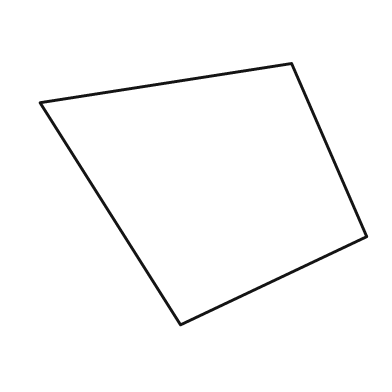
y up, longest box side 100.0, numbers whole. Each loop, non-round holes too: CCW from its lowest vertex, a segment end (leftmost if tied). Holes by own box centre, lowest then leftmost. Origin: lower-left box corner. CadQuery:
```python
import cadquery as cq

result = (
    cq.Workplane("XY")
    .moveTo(43.0, 0.0)
    .lineTo(100.0, 27.0)
    .lineTo(77.0, 80.0)
    .lineTo(0.0, 68.0)
    .close()
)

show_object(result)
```